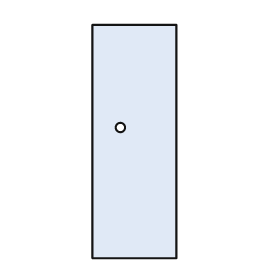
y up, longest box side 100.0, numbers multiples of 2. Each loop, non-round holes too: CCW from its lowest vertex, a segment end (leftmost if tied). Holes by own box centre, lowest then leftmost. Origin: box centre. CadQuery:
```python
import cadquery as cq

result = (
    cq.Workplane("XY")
    .moveTo(-18.0, -50.0)
    .lineTo(18.0, -50.0)
    .lineTo(18.0, 50.0)
    .lineTo(-18.0, 50.0)
    .close()
    .moveTo(-6.0, 6.0)
    .circle(2.0)
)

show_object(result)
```